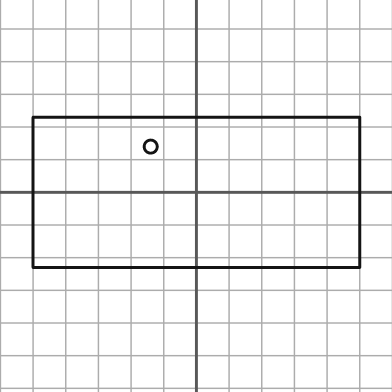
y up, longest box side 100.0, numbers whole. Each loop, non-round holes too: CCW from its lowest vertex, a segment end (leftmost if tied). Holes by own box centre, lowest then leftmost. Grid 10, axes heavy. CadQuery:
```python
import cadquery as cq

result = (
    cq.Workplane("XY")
    .moveTo(-50.0, -23.0)
    .lineTo(50.0, -23.0)
    .lineTo(50.0, 23.0)
    .lineTo(-50.0, 23.0)
    .close()
    .moveTo(-14.0, 14.0)
    .circle(2.0)
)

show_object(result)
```